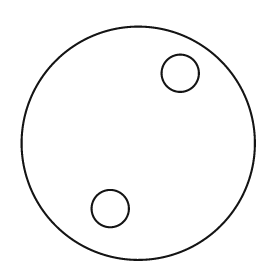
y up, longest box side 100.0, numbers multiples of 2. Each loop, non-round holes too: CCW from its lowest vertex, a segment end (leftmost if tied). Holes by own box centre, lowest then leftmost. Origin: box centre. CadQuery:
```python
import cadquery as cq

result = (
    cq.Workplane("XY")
    .moveTo(0.0, 0.0)
    .circle(50.0)
    .moveTo(-12.0, -28.0)
    .circle(8.0)
    .moveTo(18.0, 30.0)
    .circle(8.0)
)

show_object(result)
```